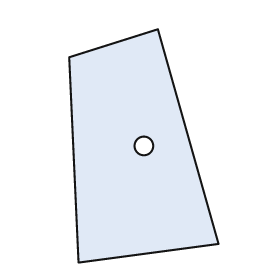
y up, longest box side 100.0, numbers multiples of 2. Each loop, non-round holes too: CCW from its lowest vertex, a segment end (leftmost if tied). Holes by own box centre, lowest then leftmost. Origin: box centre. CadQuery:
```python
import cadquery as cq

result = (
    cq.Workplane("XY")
    .moveTo(-28.0, -50.0)
    .lineTo(32.0, -42.0)
    .lineTo(6.0, 50.0)
    .lineTo(-32.0, 38.0)
    .close()
    .moveTo(0.0, 0.0)
    .circle(4.0)
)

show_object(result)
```